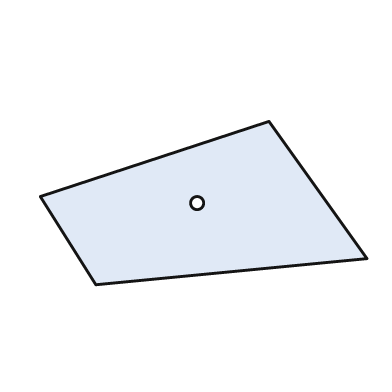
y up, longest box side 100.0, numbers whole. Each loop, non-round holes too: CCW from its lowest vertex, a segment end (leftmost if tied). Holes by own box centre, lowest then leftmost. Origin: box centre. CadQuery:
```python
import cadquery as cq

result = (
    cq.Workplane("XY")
    .moveTo(-33.0, -25.0)
    .lineTo(50.0, -17.0)
    .lineTo(20.0, 25.0)
    .lineTo(-50.0, 2.0)
    .close()
    .moveTo(-2.0, 0.0)
    .circle(2.0)
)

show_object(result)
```